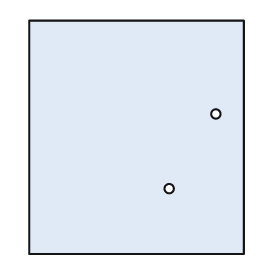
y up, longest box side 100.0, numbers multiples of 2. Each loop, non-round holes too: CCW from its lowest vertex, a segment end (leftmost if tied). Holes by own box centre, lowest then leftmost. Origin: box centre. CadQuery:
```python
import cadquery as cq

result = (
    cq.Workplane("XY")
    .moveTo(-46.0, -50.0)
    .lineTo(46.0, -50.0)
    .lineTo(46.0, 50.0)
    .lineTo(-46.0, 50.0)
    .close()
    .moveTo(14.0, -22.0)
    .circle(2.0)
    .moveTo(34.0, 10.0)
    .circle(2.0)
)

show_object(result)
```